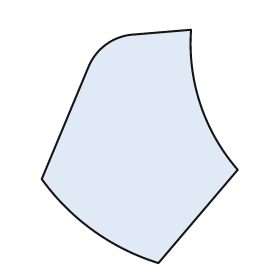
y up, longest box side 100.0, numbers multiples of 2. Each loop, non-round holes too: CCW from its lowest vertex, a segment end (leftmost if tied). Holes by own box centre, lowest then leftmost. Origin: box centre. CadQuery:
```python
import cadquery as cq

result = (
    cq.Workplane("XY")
    .moveTo(8.0, -50.0)
    .lineTo(42.0, -10.0)
    .threePointArc((26.0, 18.0), (22.0, 50.0))
    .lineTo(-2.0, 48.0)
    .threePointArc((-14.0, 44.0), (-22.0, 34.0))
    .lineTo(-42.0, -14.0)
    .threePointArc((-20.0, -36.0), (8.0, -50.0))
    .close()
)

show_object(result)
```